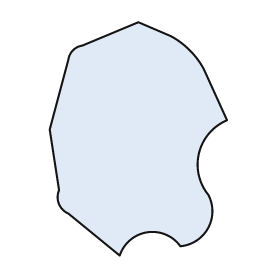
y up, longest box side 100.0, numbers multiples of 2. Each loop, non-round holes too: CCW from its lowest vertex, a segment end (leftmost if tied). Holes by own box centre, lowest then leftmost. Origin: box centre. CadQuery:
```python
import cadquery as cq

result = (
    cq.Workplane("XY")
    .moveTo(-8.0, -50.0)
    .threePointArc((4.0, -40.0), (18.0, -46.0))
    .threePointArc((30.0, -38.0), (30.0, -24.0))
    .threePointArc((26.0, -6.0), (38.0, 8.0))
    .lineTo(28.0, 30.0)
    .threePointArc((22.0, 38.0), (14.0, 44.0))
    .lineTo(0.0, 50.0)
    .lineTo(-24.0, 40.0)
    .threePointArc((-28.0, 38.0), (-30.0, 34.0))
    .lineTo(-38.0, 4.0)
    .lineTo(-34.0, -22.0)
    .threePointArc((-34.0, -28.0), (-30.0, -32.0))
    .close()
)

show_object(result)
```